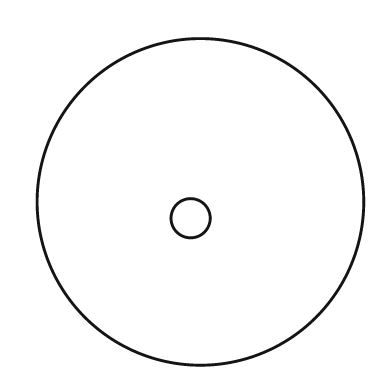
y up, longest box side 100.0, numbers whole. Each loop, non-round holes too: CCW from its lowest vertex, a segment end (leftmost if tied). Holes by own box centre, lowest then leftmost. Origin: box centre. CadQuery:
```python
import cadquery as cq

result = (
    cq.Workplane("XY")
    .moveTo(0.0, 0.0)
    .circle(50.0)
    .moveTo(-3.0, -5.0)
    .circle(6.0)
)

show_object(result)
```